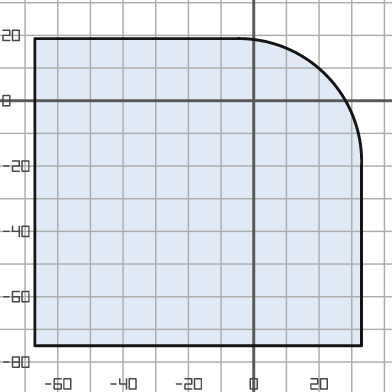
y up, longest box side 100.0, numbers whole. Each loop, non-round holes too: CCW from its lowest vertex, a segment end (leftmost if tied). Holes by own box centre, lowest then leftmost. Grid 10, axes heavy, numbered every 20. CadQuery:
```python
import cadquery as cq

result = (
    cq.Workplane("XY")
    .moveTo(-67.0, -75.0)
    .lineTo(33.0, -75.0)
    .lineTo(33.0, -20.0)
    .threePointArc((22.0, 8.0), (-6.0, 19.0))
    .lineTo(-67.0, 19.0)
    .close()
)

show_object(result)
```